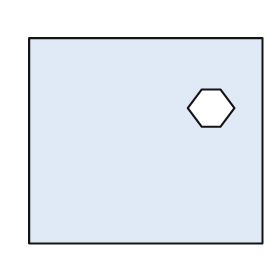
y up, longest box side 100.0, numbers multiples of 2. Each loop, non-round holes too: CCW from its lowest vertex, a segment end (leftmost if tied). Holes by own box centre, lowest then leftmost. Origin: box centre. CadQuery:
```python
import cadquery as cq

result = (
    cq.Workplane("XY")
    .moveTo(-50.0, -44.0)
    .lineTo(50.0, -44.0)
    .lineTo(50.0, 44.0)
    .lineTo(-50.0, 44.0)
    .close()
    .moveTo(24.0, 6.0)
    .lineTo(32.0, 6.0)
    .lineTo(38.0, 14.0)
    .lineTo(32.0, 22.0)
    .lineTo(24.0, 22.0)
    .lineTo(18.0, 14.0)
    .close()
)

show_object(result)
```